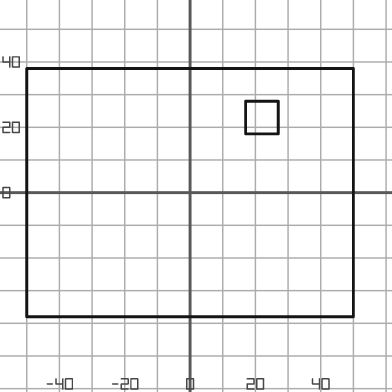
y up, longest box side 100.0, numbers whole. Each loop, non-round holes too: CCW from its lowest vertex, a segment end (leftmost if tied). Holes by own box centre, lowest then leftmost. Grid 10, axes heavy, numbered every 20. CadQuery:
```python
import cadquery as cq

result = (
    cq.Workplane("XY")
    .moveTo(-50.0, -38.0)
    .lineTo(50.0, -38.0)
    .lineTo(50.0, 38.0)
    .lineTo(-50.0, 38.0)
    .close()
    .moveTo(17.0, 18.0)
    .lineTo(27.0, 18.0)
    .lineTo(27.0, 28.0)
    .lineTo(17.0, 28.0)
    .close()
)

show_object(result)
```